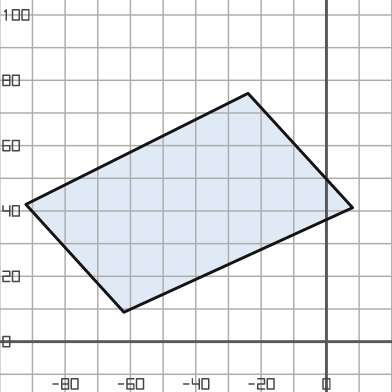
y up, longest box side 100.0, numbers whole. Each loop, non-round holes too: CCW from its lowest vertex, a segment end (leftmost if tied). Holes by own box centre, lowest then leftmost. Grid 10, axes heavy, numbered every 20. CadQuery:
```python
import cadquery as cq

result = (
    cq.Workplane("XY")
    .moveTo(-62.0, 9.0)
    .lineTo(8.0, 41.0)
    .lineTo(-24.0, 76.0)
    .lineTo(-92.0, 42.0)
    .close()
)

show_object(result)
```